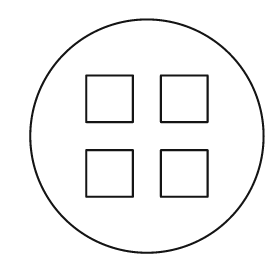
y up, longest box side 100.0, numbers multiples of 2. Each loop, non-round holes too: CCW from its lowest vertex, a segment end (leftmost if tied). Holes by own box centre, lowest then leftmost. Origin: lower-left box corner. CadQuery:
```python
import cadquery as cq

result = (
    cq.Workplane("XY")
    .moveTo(50.0, 50.0)
    .circle(50.0)
    .moveTo(24.0, 24.0)
    .lineTo(44.0, 24.0)
    .lineTo(44.0, 44.0)
    .lineTo(24.0, 44.0)
    .close()
    .moveTo(56.0, 24.0)
    .lineTo(76.0, 24.0)
    .lineTo(76.0, 44.0)
    .lineTo(56.0, 44.0)
    .close()
    .moveTo(24.0, 56.0)
    .lineTo(44.0, 56.0)
    .lineTo(44.0, 76.0)
    .lineTo(24.0, 76.0)
    .close()
    .moveTo(56.0, 56.0)
    .lineTo(76.0, 56.0)
    .lineTo(76.0, 76.0)
    .lineTo(56.0, 76.0)
    .close()
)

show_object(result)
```